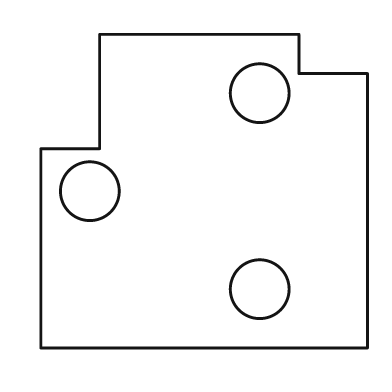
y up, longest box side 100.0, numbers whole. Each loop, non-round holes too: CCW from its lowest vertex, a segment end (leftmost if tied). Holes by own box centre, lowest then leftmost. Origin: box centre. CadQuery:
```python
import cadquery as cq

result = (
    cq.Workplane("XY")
    .moveTo(-50.0, -48.0)
    .lineTo(50.0, -48.0)
    .lineTo(50.0, 36.0)
    .lineTo(29.0, 36.0)
    .lineTo(29.0, 48.0)
    .lineTo(-32.0, 48.0)
    .lineTo(-32.0, 13.0)
    .lineTo(-50.0, 13.0)
    .close()
    .moveTo(17.0, -30.0)
    .circle(9.0)
    .moveTo(-35.0, 0.0)
    .circle(9.0)
    .moveTo(17.0, 30.0)
    .circle(9.0)
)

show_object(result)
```